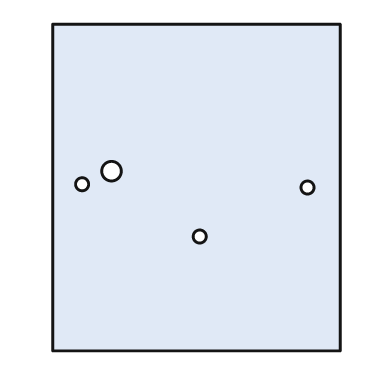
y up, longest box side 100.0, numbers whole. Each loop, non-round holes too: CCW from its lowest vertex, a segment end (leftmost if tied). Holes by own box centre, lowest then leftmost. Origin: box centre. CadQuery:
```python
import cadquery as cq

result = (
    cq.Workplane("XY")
    .moveTo(-44.0, -50.0)
    .lineTo(44.0, -50.0)
    .lineTo(44.0, 50.0)
    .lineTo(-44.0, 50.0)
    .close()
    .moveTo(1.0, -15.0)
    .circle(2.0)
    .moveTo(34.0, 0.0)
    .circle(2.0)
    .moveTo(-35.0, 1.0)
    .circle(2.0)
    .moveTo(-26.0, 5.0)
    .circle(3.0)
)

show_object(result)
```